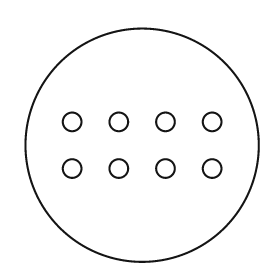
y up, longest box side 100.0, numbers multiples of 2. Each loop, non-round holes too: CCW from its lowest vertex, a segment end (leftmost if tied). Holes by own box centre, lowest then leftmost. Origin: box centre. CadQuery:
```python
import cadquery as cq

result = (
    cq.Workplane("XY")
    .moveTo(0.0, 0.0)
    .circle(50.0)
    .moveTo(-30.0, -10.0)
    .circle(4.0)
    .moveTo(-10.0, -10.0)
    .circle(4.0)
    .moveTo(10.0, -10.0)
    .circle(4.0)
    .moveTo(30.0, -10.0)
    .circle(4.0)
    .moveTo(-30.0, 10.0)
    .circle(4.0)
    .moveTo(-10.0, 10.0)
    .circle(4.0)
    .moveTo(10.0, 10.0)
    .circle(4.0)
    .moveTo(30.0, 10.0)
    .circle(4.0)
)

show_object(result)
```